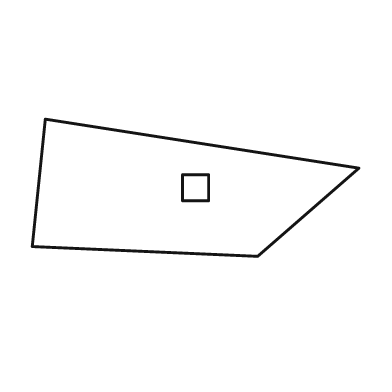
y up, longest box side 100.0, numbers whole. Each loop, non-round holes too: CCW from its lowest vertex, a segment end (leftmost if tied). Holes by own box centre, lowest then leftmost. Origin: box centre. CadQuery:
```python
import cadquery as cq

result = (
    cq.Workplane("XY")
    .moveTo(19.0, -21.0)
    .lineTo(50.0, 6.0)
    .lineTo(-46.0, 21.0)
    .lineTo(-50.0, -18.0)
    .close()
    .moveTo(-4.0, -4.0)
    .lineTo(4.0, -4.0)
    .lineTo(4.0, 4.0)
    .lineTo(-4.0, 4.0)
    .close()
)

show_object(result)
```